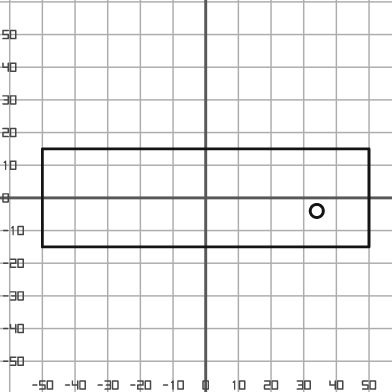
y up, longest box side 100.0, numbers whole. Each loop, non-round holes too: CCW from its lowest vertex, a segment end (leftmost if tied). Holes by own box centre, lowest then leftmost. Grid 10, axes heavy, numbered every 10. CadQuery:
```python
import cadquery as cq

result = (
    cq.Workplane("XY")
    .moveTo(-50.0, -15.0)
    .lineTo(50.0, -15.0)
    .lineTo(50.0, 15.0)
    .lineTo(-50.0, 15.0)
    .close()
    .moveTo(34.0, -4.0)
    .circle(2.0)
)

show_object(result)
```